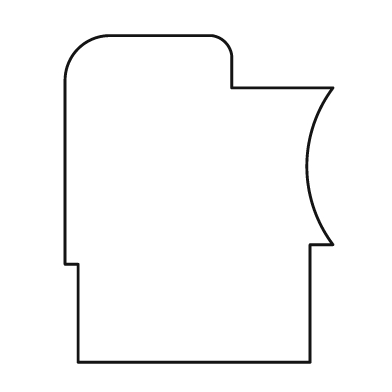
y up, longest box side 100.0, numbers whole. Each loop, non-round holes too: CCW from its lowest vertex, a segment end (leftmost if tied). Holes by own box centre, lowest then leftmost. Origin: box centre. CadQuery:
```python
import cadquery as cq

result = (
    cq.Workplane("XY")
    .moveTo(-37.0, -50.0)
    .lineTo(34.0, -50.0)
    .lineTo(34.0, -14.0)
    .lineTo(41.0, -14.0)
    .threePointArc((33.0, 10.0), (41.0, 34.0))
    .lineTo(10.0, 34.0)
    .lineTo(10.0, 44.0)
    .threePointArc((8.0, 48.0), (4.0, 50.0))
    .lineTo(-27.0, 50.0)
    .threePointArc((-37.0, 46.0), (-41.0, 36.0))
    .lineTo(-41.0, -20.0)
    .lineTo(-37.0, -20.0)
    .close()
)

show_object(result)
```